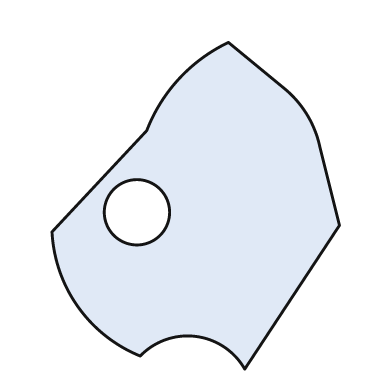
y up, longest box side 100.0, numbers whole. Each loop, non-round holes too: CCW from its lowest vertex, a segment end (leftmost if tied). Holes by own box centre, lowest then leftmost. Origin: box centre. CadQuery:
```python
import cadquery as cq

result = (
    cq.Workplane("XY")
    .moveTo(15.0, -50.0)
    .lineTo(44.0, -6.0)
    .lineTo(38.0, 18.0)
    .threePointArc((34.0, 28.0), (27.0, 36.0))
    .lineTo(10.0, 50.0)
    .threePointArc((-5.0, 39.0), (-15.0, 23.0))
    .lineTo(-44.0, -8.0)
    .threePointArc((-36.0, -31.0), (-17.0, -46.0))
    .threePointArc((0.0, -40.0), (15.0, -50.0))
    .close()
    .moveTo(-18.0, -2.0)
    .circle(10.0)
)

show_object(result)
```